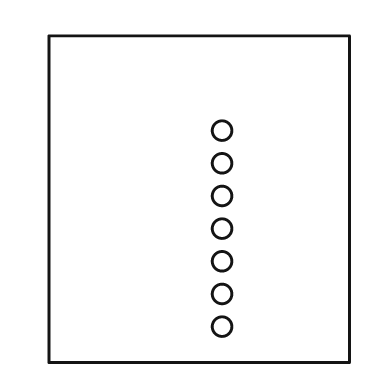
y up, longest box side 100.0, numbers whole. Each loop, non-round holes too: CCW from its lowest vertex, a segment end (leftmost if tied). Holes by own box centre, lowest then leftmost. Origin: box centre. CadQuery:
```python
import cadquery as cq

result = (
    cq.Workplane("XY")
    .moveTo(-46.0, -50.0)
    .lineTo(46.0, -50.0)
    .lineTo(46.0, 50.0)
    .lineTo(-46.0, 50.0)
    .close()
    .moveTo(7.0, -39.0)
    .circle(3.0)
    .moveTo(7.0, -29.0)
    .circle(3.0)
    .moveTo(7.0, -19.0)
    .circle(3.0)
    .moveTo(7.0, -9.0)
    .circle(3.0)
    .moveTo(7.0, 1.0)
    .circle(3.0)
    .moveTo(7.0, 11.0)
    .circle(3.0)
    .moveTo(7.0, 21.0)
    .circle(3.0)
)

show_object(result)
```